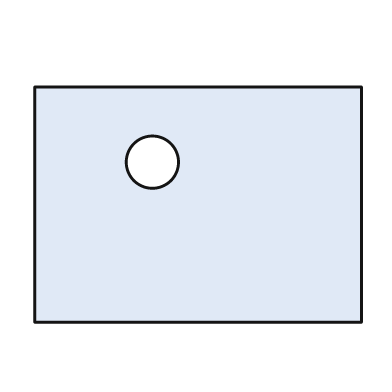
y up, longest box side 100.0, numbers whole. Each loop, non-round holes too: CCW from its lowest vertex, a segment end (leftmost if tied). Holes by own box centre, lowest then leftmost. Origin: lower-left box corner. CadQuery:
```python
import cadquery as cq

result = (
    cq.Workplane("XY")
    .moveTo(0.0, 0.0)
    .lineTo(100.0, 0.0)
    .lineTo(100.0, 72.0)
    .lineTo(0.0, 72.0)
    .close()
    .moveTo(36.0, 49.0)
    .circle(8.0)
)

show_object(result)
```